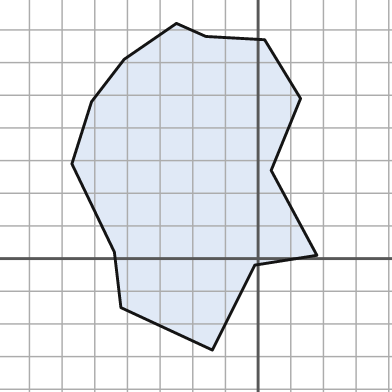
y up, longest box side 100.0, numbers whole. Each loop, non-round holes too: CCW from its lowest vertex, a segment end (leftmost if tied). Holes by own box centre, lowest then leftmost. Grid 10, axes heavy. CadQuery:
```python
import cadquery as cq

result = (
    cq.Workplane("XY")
    .moveTo(-14.0, -28.0)
    .lineTo(-1.0, -2.0)
    .lineTo(18.0, 1.0)
    .lineTo(4.0, 27.0)
    .lineTo(13.0, 49.0)
    .lineTo(2.0, 67.0)
    .lineTo(-16.0, 68.0)
    .lineTo(-25.0, 72.0)
    .lineTo(-41.0, 61.0)
    .lineTo(-51.0, 48.0)
    .lineTo(-57.0, 29.0)
    .lineTo(-44.0, 2.0)
    .lineTo(-42.0, -15.0)
    .close()
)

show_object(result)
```